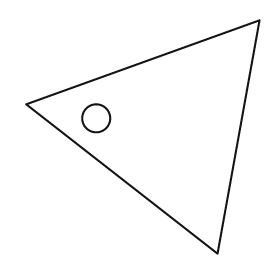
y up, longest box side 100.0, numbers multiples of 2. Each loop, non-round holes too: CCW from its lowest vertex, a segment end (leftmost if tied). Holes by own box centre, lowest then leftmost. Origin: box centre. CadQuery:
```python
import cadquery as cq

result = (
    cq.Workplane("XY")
    .moveTo(32.0, -50.0)
    .lineTo(50.0, 50.0)
    .lineTo(-50.0, 14.0)
    .close()
    .moveTo(-20.0, 8.0)
    .circle(6.0)
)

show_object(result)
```